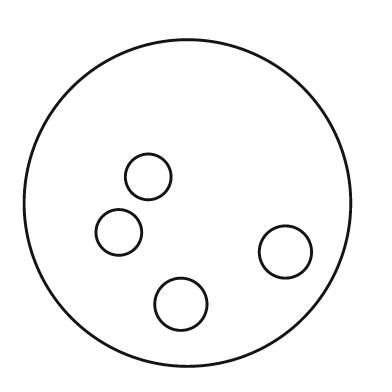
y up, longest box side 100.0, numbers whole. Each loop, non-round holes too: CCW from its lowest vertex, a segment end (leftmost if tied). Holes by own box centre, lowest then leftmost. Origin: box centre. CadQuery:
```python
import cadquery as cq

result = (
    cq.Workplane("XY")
    .moveTo(0.0, 0.0)
    .circle(50.0)
    .moveTo(-2.0, -31.0)
    .circle(8.0)
    .moveTo(30.0, -15.0)
    .circle(8.0)
    .moveTo(-21.0, -9.0)
    .circle(7.0)
    .moveTo(-12.0, 8.0)
    .circle(7.0)
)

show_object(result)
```